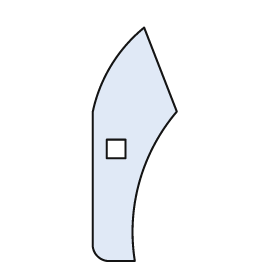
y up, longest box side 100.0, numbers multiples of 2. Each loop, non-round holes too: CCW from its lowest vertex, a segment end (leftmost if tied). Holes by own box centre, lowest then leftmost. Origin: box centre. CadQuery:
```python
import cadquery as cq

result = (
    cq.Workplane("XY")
    .moveTo(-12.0, -50.0)
    .lineTo(0.0, -50.0)
    .threePointArc((2.0, -16.0), (18.0, 14.0))
    .lineTo(4.0, 50.0)
    .threePointArc((-10.0, 34.0), (-18.0, 14.0))
    .lineTo(-18.0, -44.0)
    .threePointArc((-16.0, -48.0), (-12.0, -50.0))
    .close()
    .moveTo(-12.0, -6.0)
    .lineTo(-4.0, -6.0)
    .lineTo(-4.0, 2.0)
    .lineTo(-12.0, 2.0)
    .close()
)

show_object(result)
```